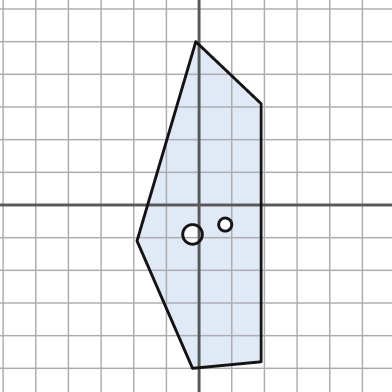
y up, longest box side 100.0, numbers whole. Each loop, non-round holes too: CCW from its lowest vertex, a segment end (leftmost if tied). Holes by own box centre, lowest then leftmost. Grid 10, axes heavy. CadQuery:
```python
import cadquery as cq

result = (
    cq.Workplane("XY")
    .moveTo(-2.0, -50.0)
    .lineTo(19.0, -48.0)
    .lineTo(19.0, 31.0)
    .lineTo(-1.0, 50.0)
    .lineTo(-19.0, -11.0)
    .close()
    .moveTo(-2.0, -9.0)
    .circle(3.0)
    .moveTo(8.0, -6.0)
    .circle(2.0)
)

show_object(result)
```